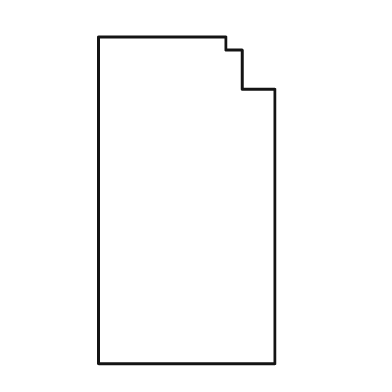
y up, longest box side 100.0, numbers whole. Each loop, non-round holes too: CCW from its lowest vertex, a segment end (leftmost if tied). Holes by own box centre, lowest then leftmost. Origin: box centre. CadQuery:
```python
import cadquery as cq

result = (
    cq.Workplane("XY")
    .moveTo(-27.0, -50.0)
    .lineTo(27.0, -50.0)
    .lineTo(27.0, 34.0)
    .lineTo(17.0, 34.0)
    .lineTo(17.0, 46.0)
    .lineTo(12.0, 46.0)
    .lineTo(12.0, 50.0)
    .lineTo(-27.0, 50.0)
    .close()
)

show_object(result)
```